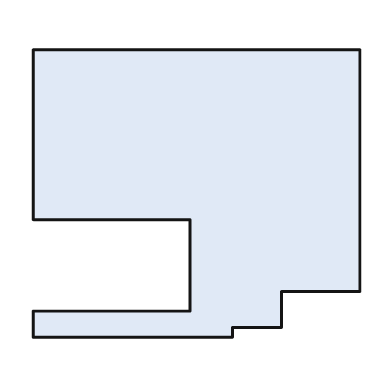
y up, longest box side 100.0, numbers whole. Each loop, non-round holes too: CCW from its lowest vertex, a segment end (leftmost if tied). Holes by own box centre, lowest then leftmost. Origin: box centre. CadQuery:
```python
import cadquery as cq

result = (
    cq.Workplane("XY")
    .moveTo(-50.0, -44.0)
    .lineTo(11.0, -44.0)
    .lineTo(11.0, -41.0)
    .lineTo(26.0, -41.0)
    .lineTo(26.0, -30.0)
    .lineTo(50.0, -30.0)
    .lineTo(50.0, 44.0)
    .lineTo(-50.0, 44.0)
    .lineTo(-50.0, -8.0)
    .lineTo(-2.0, -8.0)
    .lineTo(-2.0, -36.0)
    .lineTo(-50.0, -36.0)
    .close()
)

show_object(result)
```